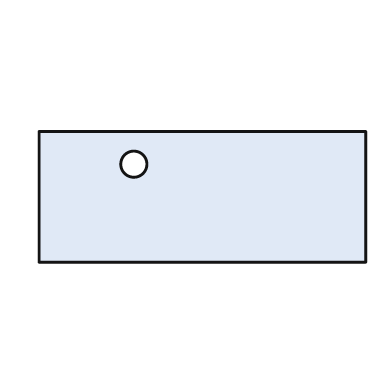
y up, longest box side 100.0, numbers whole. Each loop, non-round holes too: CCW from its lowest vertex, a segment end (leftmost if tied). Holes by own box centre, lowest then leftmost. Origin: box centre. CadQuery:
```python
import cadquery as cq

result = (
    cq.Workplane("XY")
    .moveTo(-50.0, -20.0)
    .lineTo(50.0, -20.0)
    .lineTo(50.0, 20.0)
    .lineTo(-50.0, 20.0)
    .close()
    .moveTo(-21.0, 10.0)
    .circle(4.0)
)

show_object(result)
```